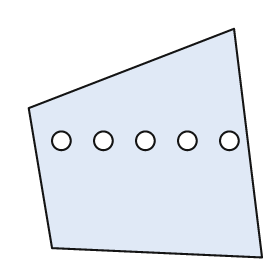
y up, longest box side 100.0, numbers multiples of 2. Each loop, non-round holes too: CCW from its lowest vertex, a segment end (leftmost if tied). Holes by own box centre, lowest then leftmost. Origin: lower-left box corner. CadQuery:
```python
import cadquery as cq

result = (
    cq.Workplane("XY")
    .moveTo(100.0, 0.0)
    .lineTo(88.0, 98.0)
    .lineTo(0.0, 64.0)
    .lineTo(10.0, 4.0)
    .close()
    .moveTo(14.0, 50.0)
    .circle(4.0)
    .moveTo(32.0, 50.0)
    .circle(4.0)
    .moveTo(50.0, 50.0)
    .circle(4.0)
    .moveTo(68.0, 50.0)
    .circle(4.0)
    .moveTo(86.0, 50.0)
    .circle(4.0)
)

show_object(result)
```